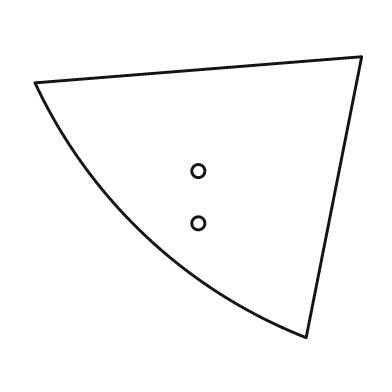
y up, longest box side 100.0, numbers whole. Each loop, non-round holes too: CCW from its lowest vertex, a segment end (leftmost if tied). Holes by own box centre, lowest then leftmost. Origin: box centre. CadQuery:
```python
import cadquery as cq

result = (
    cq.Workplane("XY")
    .moveTo(33.0, -43.0)
    .lineTo(50.0, 43.0)
    .lineTo(-50.0, 35.0)
    .threePointArc((-16.0, -12.0), (33.0, -43.0))
    .close()
    .moveTo(0.0, -8.0)
    .circle(2.0)
    .moveTo(0.0, 8.0)
    .circle(2.0)
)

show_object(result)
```